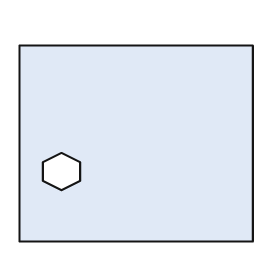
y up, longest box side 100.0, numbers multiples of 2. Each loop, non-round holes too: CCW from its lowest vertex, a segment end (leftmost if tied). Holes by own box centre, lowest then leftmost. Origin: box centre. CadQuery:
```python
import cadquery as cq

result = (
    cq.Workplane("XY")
    .moveTo(-50.0, -42.0)
    .lineTo(50.0, -42.0)
    .lineTo(50.0, 42.0)
    .lineTo(-50.0, 42.0)
    .close()
    .moveTo(-32.0, -20.0)
    .lineTo(-24.0, -16.0)
    .lineTo(-24.0, -8.0)
    .lineTo(-32.0, -4.0)
    .lineTo(-40.0, -8.0)
    .lineTo(-40.0, -16.0)
    .close()
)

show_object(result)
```